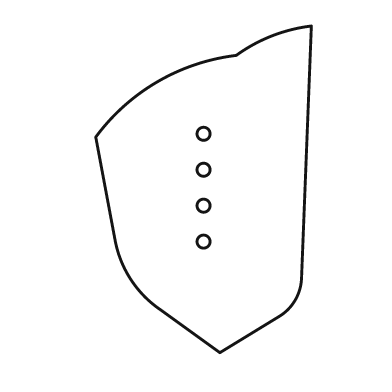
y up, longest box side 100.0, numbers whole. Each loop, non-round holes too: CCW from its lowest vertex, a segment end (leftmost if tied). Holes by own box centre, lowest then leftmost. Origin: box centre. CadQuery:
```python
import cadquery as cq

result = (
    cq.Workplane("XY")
    .moveTo(5.0, -50.0)
    .lineTo(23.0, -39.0)
    .threePointArc((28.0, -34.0), (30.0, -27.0))
    .lineTo(33.0, 50.0)
    .threePointArc((21.0, 47.0), (10.0, 41.0))
    .threePointArc((-14.0, 33.0), (-33.0, 16.0))
    .lineTo(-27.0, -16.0)
    .threePointArc((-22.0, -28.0), (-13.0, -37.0))
    .close()
    .moveTo(0.0, -16.0)
    .circle(2.0)
    .moveTo(0.0, -5.0)
    .circle(2.0)
    .moveTo(0.0, 6.0)
    .circle(2.0)
    .moveTo(0.0, 17.0)
    .circle(2.0)
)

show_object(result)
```